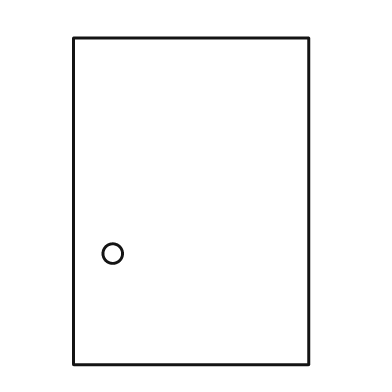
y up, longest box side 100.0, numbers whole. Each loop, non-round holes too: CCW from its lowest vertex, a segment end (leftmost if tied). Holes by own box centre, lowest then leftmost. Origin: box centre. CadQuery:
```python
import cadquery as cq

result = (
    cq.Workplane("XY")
    .moveTo(-36.0, -50.0)
    .lineTo(36.0, -50.0)
    .lineTo(36.0, 50.0)
    .lineTo(-36.0, 50.0)
    .close()
    .moveTo(-24.0, -16.0)
    .circle(3.0)
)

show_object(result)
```